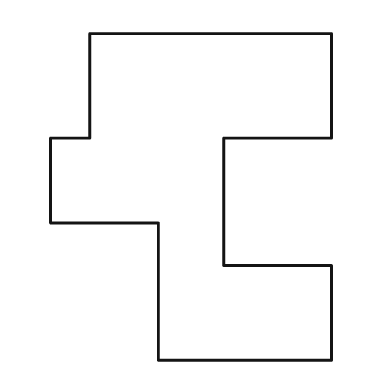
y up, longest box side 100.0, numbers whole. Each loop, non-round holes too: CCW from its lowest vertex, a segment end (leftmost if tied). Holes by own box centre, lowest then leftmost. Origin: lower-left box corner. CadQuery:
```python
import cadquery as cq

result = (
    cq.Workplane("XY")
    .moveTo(33.0, 0.0)
    .lineTo(86.0, 0.0)
    .lineTo(86.0, 29.0)
    .lineTo(53.0, 29.0)
    .lineTo(53.0, 68.0)
    .lineTo(86.0, 68.0)
    .lineTo(86.0, 100.0)
    .lineTo(12.0, 100.0)
    .lineTo(12.0, 68.0)
    .lineTo(0.0, 68.0)
    .lineTo(0.0, 42.0)
    .lineTo(33.0, 42.0)
    .close()
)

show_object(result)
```